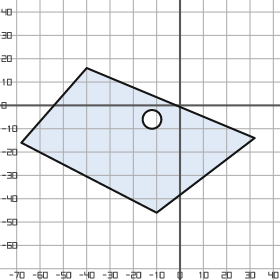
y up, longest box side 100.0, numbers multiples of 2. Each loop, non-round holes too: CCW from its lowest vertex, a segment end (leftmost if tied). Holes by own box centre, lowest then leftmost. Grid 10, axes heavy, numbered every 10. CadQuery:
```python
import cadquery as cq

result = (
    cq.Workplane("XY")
    .moveTo(-10.0, -46.0)
    .lineTo(32.0, -14.0)
    .lineTo(-40.0, 16.0)
    .lineTo(-68.0, -16.0)
    .close()
    .moveTo(-12.0, -6.0)
    .circle(4.0)
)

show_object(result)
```